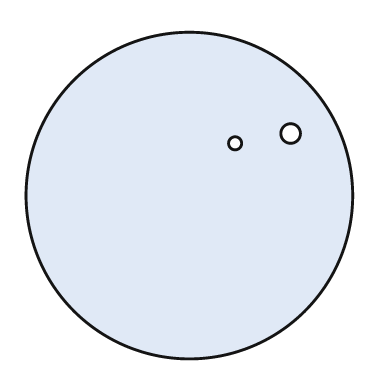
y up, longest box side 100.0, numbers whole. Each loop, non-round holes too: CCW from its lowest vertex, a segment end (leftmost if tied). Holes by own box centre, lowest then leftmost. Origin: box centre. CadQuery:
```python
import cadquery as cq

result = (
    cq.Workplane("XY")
    .moveTo(0.0, 0.0)
    .circle(50.0)
    .moveTo(14.0, 16.0)
    .circle(2.0)
    .moveTo(31.0, 19.0)
    .circle(3.0)
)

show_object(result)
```